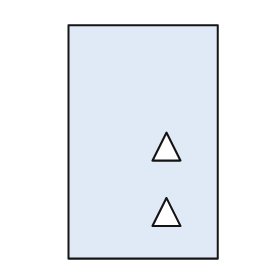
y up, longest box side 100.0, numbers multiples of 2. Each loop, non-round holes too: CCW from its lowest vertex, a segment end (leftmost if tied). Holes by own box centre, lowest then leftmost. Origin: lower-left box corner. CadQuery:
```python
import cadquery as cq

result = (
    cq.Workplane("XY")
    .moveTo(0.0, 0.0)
    .lineTo(64.0, 0.0)
    .lineTo(64.0, 100.0)
    .lineTo(0.0, 100.0)
    .close()
    .moveTo(36.0, 14.0)
    .lineTo(48.0, 14.0)
    .lineTo(42.0, 26.0)
    .close()
    .moveTo(36.0, 42.0)
    .lineTo(48.0, 42.0)
    .lineTo(42.0, 54.0)
    .close()
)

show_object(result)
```